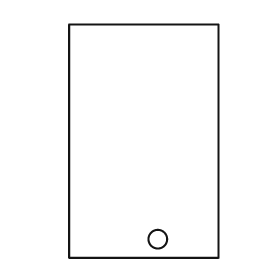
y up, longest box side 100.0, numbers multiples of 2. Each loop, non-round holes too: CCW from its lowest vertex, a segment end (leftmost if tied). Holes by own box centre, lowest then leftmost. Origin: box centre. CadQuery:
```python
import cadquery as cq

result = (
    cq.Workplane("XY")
    .moveTo(-32.0, -50.0)
    .lineTo(32.0, -50.0)
    .lineTo(32.0, 50.0)
    .lineTo(-32.0, 50.0)
    .close()
    .moveTo(6.0, -42.0)
    .circle(4.0)
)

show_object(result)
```